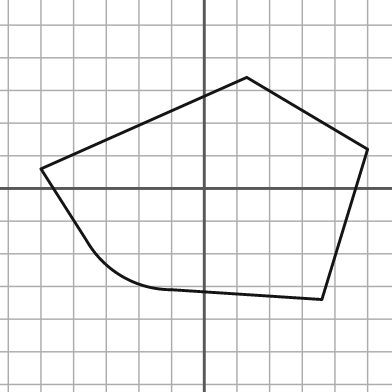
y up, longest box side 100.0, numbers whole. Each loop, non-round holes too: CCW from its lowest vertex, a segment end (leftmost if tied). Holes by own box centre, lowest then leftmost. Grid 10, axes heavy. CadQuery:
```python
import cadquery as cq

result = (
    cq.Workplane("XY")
    .moveTo(36.0, -34.0)
    .lineTo(50.0, 12.0)
    .lineTo(13.0, 34.0)
    .lineTo(-50.0, 6.0)
    .lineTo(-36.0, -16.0)
    .threePointArc((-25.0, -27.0), (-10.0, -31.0))
    .close()
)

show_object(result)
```